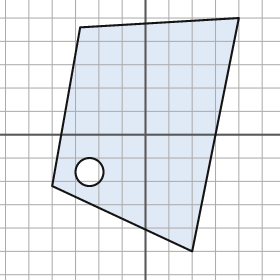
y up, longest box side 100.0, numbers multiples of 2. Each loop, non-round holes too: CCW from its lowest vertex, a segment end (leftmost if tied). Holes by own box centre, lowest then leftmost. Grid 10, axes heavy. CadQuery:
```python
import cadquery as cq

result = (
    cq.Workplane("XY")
    .moveTo(20.0, -50.0)
    .lineTo(40.0, 50.0)
    .lineTo(-28.0, 46.0)
    .lineTo(-40.0, -22.0)
    .close()
    .moveTo(-24.0, -16.0)
    .circle(6.0)
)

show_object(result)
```